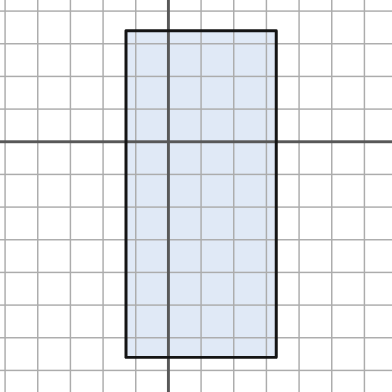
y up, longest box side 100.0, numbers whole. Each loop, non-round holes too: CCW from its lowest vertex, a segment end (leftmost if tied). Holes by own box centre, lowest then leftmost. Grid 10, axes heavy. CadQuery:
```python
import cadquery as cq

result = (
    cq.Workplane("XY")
    .moveTo(-13.0, -66.0)
    .lineTo(33.0, -66.0)
    .lineTo(33.0, 34.0)
    .lineTo(-13.0, 34.0)
    .close()
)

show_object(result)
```